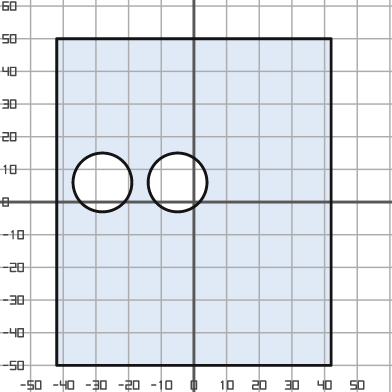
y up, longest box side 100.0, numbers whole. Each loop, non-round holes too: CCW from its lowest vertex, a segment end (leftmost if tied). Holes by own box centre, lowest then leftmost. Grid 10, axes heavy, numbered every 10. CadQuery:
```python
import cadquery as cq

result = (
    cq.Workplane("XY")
    .moveTo(-42.0, -50.0)
    .lineTo(42.0, -50.0)
    .lineTo(42.0, 50.0)
    .lineTo(-42.0, 50.0)
    .close()
    .moveTo(-28.0, 6.0)
    .circle(9.0)
    .moveTo(-5.0, 6.0)
    .circle(9.0)
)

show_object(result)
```